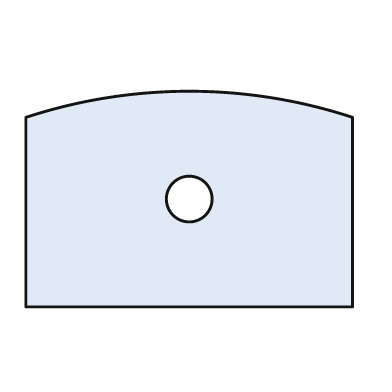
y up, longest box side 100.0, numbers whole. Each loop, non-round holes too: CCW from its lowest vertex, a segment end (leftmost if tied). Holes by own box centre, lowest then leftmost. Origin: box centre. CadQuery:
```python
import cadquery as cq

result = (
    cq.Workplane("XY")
    .moveTo(-50.0, -33.0)
    .lineTo(50.0, -33.0)
    .lineTo(50.0, 25.0)
    .threePointArc((0.0, 33.0), (-50.0, 25.0))
    .close()
    .moveTo(0.0, 0.0)
    .circle(7.0)
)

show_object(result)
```